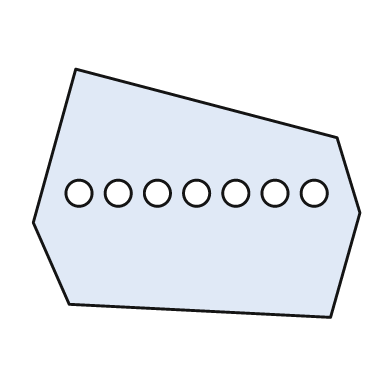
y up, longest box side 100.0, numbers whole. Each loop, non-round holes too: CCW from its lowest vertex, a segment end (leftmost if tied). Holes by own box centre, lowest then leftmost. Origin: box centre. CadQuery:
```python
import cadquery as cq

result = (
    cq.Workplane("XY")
    .moveTo(41.0, -38.0)
    .lineTo(50.0, -6.0)
    .lineTo(43.0, 17.0)
    .lineTo(-37.0, 38.0)
    .lineTo(-50.0, -9.0)
    .lineTo(-39.0, -34.0)
    .close()
    .moveTo(-36.0, 0.0)
    .circle(4.0)
    .moveTo(-24.0, 0.0)
    .circle(4.0)
    .moveTo(-12.0, 0.0)
    .circle(4.0)
    .moveTo(0.0, 0.0)
    .circle(4.0)
    .moveTo(12.0, 0.0)
    .circle(4.0)
    .moveTo(24.0, 0.0)
    .circle(4.0)
    .moveTo(36.0, 0.0)
    .circle(4.0)
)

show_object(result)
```